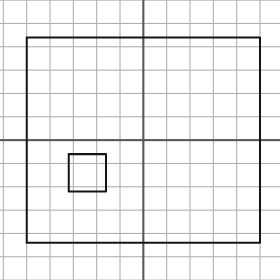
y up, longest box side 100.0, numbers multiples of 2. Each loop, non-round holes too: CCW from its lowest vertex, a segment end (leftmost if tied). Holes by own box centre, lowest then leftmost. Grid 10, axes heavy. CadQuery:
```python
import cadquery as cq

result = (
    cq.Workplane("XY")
    .moveTo(-50.0, -44.0)
    .lineTo(50.0, -44.0)
    .lineTo(50.0, 44.0)
    .lineTo(-50.0, 44.0)
    .close()
    .moveTo(-32.0, -22.0)
    .lineTo(-16.0, -22.0)
    .lineTo(-16.0, -6.0)
    .lineTo(-32.0, -6.0)
    .close()
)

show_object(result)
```